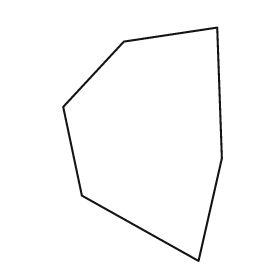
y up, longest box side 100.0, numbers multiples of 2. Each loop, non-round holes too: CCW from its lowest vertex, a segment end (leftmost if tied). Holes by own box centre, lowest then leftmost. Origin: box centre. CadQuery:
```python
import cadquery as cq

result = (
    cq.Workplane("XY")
    .moveTo(24.0, -50.0)
    .lineTo(34.0, -6.0)
    .lineTo(32.0, 50.0)
    .lineTo(-8.0, 44.0)
    .lineTo(-34.0, 16.0)
    .lineTo(-26.0, -22.0)
    .close()
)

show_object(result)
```